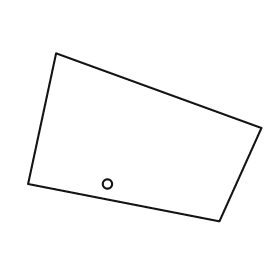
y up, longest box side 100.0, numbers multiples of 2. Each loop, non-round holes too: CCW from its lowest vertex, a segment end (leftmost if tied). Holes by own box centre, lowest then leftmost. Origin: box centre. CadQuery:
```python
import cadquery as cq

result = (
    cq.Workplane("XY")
    .moveTo(32.0, -36.0)
    .lineTo(50.0, 4.0)
    .lineTo(-38.0, 36.0)
    .lineTo(-50.0, -20.0)
    .close()
    .moveTo(-16.0, -20.0)
    .circle(2.0)
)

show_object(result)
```